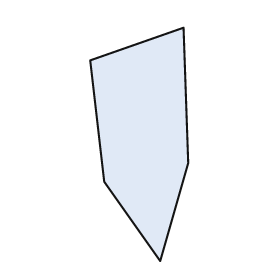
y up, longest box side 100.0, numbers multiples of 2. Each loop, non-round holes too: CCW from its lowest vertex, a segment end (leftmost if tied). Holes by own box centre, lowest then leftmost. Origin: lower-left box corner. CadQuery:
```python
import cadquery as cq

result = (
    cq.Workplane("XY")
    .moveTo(30.0, 0.0)
    .lineTo(42.0, 42.0)
    .lineTo(40.0, 100.0)
    .lineTo(0.0, 86.0)
    .lineTo(6.0, 34.0)
    .close()
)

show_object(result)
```